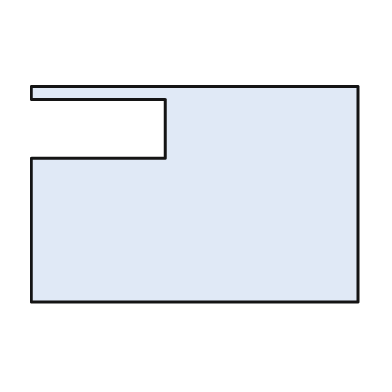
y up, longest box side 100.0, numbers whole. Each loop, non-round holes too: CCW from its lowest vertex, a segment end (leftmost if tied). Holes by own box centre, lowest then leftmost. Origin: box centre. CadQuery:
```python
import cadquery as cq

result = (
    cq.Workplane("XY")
    .moveTo(-50.0, -33.0)
    .lineTo(50.0, -33.0)
    .lineTo(50.0, 33.0)
    .lineTo(-50.0, 33.0)
    .lineTo(-50.0, 29.0)
    .lineTo(-9.0, 29.0)
    .lineTo(-9.0, 11.0)
    .lineTo(-50.0, 11.0)
    .close()
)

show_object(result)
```